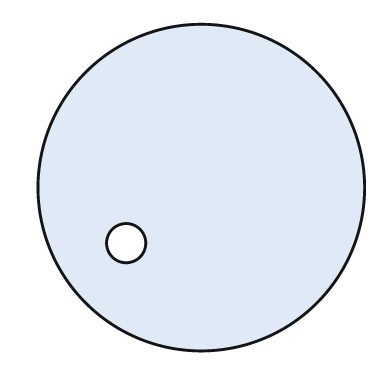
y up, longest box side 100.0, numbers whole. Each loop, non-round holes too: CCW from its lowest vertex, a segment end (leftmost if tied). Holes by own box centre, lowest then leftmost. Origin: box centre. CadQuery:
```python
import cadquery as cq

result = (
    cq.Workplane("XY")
    .moveTo(0.0, 0.0)
    .circle(50.0)
    .moveTo(-23.0, -17.0)
    .circle(6.0)
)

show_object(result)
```